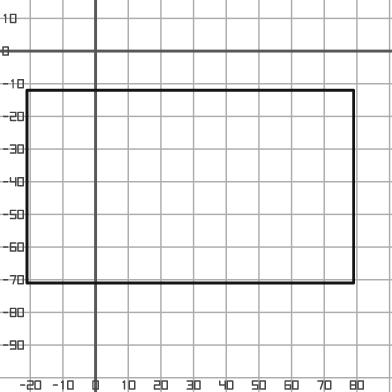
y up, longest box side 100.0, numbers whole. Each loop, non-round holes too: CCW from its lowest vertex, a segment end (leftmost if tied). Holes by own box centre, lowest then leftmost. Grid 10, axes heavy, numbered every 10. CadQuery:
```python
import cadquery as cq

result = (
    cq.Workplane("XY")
    .moveTo(-21.0, -71.0)
    .lineTo(79.0, -71.0)
    .lineTo(79.0, -12.0)
    .lineTo(-21.0, -12.0)
    .close()
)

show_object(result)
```